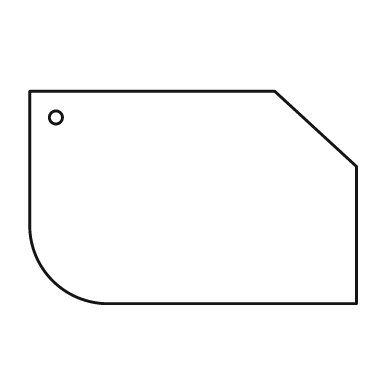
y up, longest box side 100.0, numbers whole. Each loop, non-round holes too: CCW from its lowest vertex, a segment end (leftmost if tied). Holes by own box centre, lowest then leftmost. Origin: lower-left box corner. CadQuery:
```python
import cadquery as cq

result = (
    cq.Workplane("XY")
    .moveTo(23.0, 0.0)
    .lineTo(100.0, 0.0)
    .lineTo(100.0, 42.0)
    .lineTo(75.0, 65.0)
    .lineTo(0.0, 65.0)
    .lineTo(0.0, 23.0)
    .threePointArc((7.0, 7.0), (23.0, 0.0))
    .close()
    .moveTo(8.0, 57.0)
    .circle(2.0)
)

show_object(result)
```